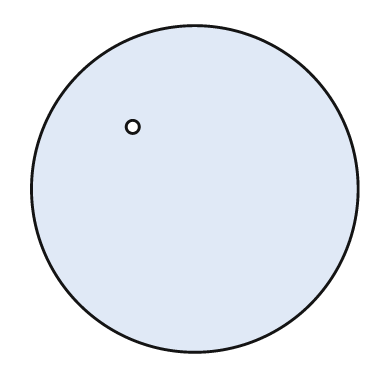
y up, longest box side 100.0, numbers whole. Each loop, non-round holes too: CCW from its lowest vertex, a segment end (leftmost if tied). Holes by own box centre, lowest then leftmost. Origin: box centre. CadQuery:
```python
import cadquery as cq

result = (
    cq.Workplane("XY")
    .moveTo(0.0, 0.0)
    .circle(50.0)
    .moveTo(-19.0, 19.0)
    .circle(2.0)
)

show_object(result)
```